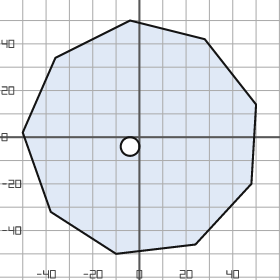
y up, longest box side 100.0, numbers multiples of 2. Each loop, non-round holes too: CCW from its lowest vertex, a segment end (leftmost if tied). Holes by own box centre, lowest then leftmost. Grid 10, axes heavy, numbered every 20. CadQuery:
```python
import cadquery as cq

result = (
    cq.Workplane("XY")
    .moveTo(-10.0, -50.0)
    .lineTo(24.0, -46.0)
    .lineTo(48.0, -20.0)
    .lineTo(50.0, 14.0)
    .lineTo(28.0, 42.0)
    .lineTo(-4.0, 50.0)
    .lineTo(-36.0, 34.0)
    .lineTo(-50.0, 2.0)
    .lineTo(-38.0, -32.0)
    .close()
    .moveTo(-4.0, -4.0)
    .circle(4.0)
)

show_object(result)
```